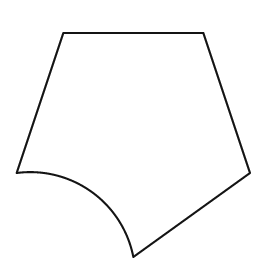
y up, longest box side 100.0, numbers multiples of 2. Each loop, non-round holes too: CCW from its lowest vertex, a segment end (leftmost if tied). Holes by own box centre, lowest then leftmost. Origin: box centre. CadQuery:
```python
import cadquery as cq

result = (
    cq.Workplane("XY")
    .moveTo(0.0, -48.0)
    .lineTo(50.0, -12.0)
    .lineTo(30.0, 48.0)
    .lineTo(-30.0, 48.0)
    .lineTo(-50.0, -12.0)
    .threePointArc((-18.0, -20.0), (0.0, -48.0))
    .close()
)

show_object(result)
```